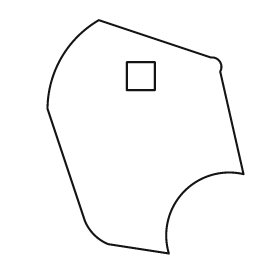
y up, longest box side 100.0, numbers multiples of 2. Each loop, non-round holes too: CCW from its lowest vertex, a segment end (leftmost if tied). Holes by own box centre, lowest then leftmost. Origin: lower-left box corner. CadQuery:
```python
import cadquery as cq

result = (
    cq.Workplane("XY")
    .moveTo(52.0, 0.0)
    .threePointArc((58.0, 26.0), (84.0, 34.0))
    .lineTo(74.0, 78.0)
    .threePointArc((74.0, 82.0), (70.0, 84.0))
    .lineTo(22.0, 100.0)
    .threePointArc((6.0, 84.0), (0.0, 62.0))
    .lineTo(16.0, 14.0)
    .threePointArc((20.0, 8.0), (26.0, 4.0))
    .close()
    .moveTo(34.0, 70.0)
    .lineTo(46.0, 70.0)
    .lineTo(46.0, 82.0)
    .lineTo(34.0, 82.0)
    .close()
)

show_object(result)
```